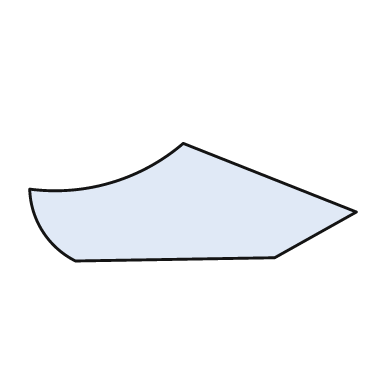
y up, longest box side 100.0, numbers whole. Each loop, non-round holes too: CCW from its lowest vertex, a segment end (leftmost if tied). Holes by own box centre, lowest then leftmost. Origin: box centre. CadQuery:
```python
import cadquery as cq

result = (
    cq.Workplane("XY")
    .moveTo(-36.0, -18.0)
    .lineTo(25.0, -17.0)
    .lineTo(50.0, -3.0)
    .lineTo(-3.0, 18.0)
    .threePointArc((-25.0, 6.0), (-50.0, 4.0))
    .threePointArc((-46.0, -9.0), (-36.0, -18.0))
    .close()
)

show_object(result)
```